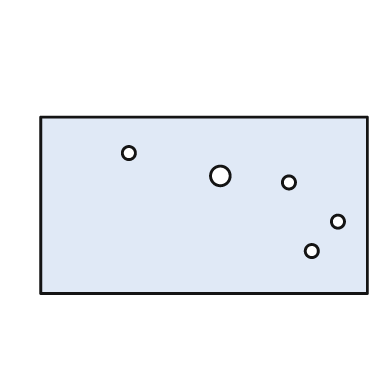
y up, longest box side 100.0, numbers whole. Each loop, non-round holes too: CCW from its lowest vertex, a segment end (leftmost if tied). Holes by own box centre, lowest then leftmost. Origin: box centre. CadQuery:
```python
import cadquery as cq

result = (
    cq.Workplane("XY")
    .moveTo(-50.0, -27.0)
    .lineTo(50.0, -27.0)
    .lineTo(50.0, 27.0)
    .lineTo(-50.0, 27.0)
    .close()
    .moveTo(33.0, -14.0)
    .circle(2.0)
    .moveTo(41.0, -5.0)
    .circle(2.0)
    .moveTo(26.0, 7.0)
    .circle(2.0)
    .moveTo(5.0, 9.0)
    .circle(3.0)
    .moveTo(-23.0, 16.0)
    .circle(2.0)
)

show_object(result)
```